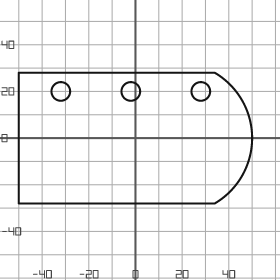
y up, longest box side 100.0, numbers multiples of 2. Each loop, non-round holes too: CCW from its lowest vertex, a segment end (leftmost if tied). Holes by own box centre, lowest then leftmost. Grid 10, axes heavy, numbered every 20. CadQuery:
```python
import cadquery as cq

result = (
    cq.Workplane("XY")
    .moveTo(-50.0, -28.0)
    .lineTo(34.0, -28.0)
    .threePointArc((50.0, 0.0), (34.0, 28.0))
    .lineTo(-50.0, 28.0)
    .close()
    .moveTo(-32.0, 20.0)
    .circle(4.0)
    .moveTo(-2.0, 20.0)
    .circle(4.0)
    .moveTo(28.0, 20.0)
    .circle(4.0)
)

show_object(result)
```